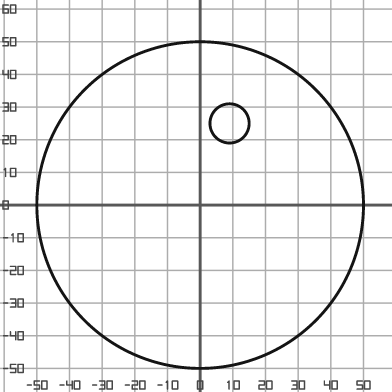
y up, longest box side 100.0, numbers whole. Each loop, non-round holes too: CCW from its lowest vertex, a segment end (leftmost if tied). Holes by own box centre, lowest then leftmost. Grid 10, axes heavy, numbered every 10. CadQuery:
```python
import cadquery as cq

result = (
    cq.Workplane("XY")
    .moveTo(0.0, 0.0)
    .circle(50.0)
    .moveTo(9.0, 25.0)
    .circle(6.0)
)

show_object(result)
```